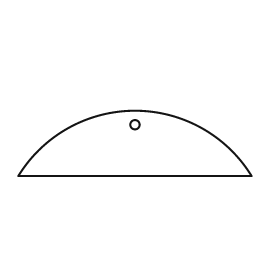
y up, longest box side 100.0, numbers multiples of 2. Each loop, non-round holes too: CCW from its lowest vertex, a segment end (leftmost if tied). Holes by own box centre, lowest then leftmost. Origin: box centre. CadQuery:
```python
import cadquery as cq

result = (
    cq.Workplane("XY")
    .moveTo(-50.0, -14.0)
    .lineTo(50.0, -14.0)
    .threePointArc((0.0, 14.0), (-50.0, -14.0))
    .close()
    .moveTo(0.0, 8.0)
    .circle(2.0)
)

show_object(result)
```